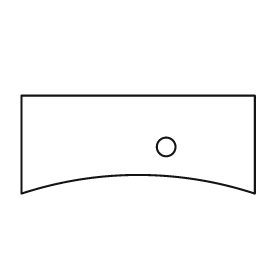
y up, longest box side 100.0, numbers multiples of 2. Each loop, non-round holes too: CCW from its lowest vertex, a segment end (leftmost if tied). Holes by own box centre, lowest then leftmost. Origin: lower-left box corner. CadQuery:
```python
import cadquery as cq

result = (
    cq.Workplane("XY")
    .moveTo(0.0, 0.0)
    .threePointArc((50.0, 8.0), (100.0, 0.0))
    .lineTo(100.0, 42.0)
    .lineTo(0.0, 42.0)
    .close()
    .moveTo(62.0, 20.0)
    .circle(4.0)
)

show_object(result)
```